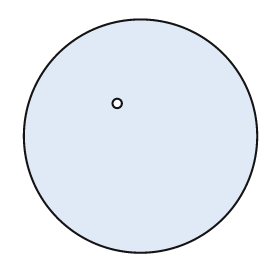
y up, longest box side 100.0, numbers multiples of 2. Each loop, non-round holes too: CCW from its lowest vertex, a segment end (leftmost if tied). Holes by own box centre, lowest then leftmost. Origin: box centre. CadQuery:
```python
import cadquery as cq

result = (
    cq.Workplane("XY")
    .moveTo(0.0, 0.0)
    .circle(50.0)
    .moveTo(-10.0, 14.0)
    .circle(2.0)
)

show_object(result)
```